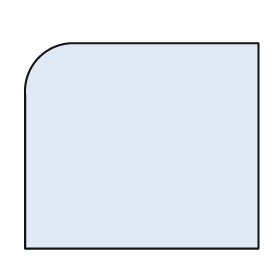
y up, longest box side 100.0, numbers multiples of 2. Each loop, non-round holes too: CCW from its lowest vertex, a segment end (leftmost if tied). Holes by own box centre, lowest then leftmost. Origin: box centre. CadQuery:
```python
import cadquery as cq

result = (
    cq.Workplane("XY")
    .moveTo(-50.0, -44.0)
    .lineTo(50.0, -44.0)
    .lineTo(50.0, 44.0)
    .lineTo(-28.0, 44.0)
    .threePointArc((-44.0, 38.0), (-50.0, 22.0))
    .close()
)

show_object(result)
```